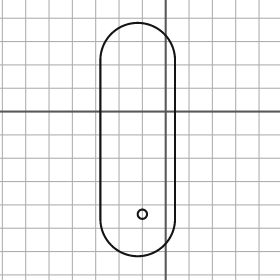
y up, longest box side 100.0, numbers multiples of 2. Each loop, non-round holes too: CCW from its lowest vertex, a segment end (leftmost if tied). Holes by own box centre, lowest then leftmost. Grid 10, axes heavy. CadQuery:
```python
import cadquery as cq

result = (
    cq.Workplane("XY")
    .moveTo(-28.0, -46.0)
    .threePointArc((-12.0, -62.0), (4.0, -46.0))
    .lineTo(4.0, 22.0)
    .threePointArc((-12.0, 38.0), (-28.0, 22.0))
    .close()
    .moveTo(-10.0, -44.0)
    .circle(2.0)
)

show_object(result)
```